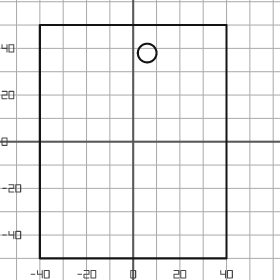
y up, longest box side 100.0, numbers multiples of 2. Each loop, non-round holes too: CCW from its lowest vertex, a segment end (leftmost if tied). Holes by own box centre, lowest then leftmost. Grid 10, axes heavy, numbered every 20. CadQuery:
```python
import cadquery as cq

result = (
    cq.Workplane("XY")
    .moveTo(-40.0, -50.0)
    .lineTo(40.0, -50.0)
    .lineTo(40.0, 50.0)
    .lineTo(-40.0, 50.0)
    .close()
    .moveTo(6.0, 38.0)
    .circle(4.0)
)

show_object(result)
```